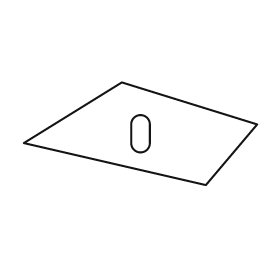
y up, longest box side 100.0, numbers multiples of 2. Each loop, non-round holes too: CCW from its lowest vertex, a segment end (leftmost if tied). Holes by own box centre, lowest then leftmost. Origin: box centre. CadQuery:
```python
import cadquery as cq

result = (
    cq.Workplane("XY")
    .moveTo(28.0, -22.0)
    .lineTo(50.0, 4.0)
    .lineTo(-8.0, 22.0)
    .lineTo(-50.0, -4.0)
    .close()
    .moveTo(-4.0, -4.0)
    .threePointArc((0.0, -8.0), (4.0, -4.0))
    .lineTo(4.0, 4.0)
    .threePointArc((0.0, 8.0), (-4.0, 4.0))
    .close()
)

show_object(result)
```